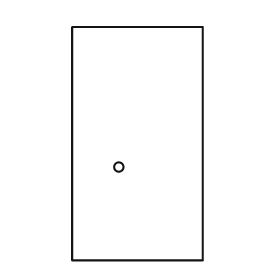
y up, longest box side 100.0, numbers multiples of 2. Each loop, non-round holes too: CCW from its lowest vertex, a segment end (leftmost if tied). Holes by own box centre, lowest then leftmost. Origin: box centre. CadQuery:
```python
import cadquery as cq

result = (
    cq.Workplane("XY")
    .moveTo(-28.0, -50.0)
    .lineTo(28.0, -50.0)
    .lineTo(28.0, 50.0)
    .lineTo(-28.0, 50.0)
    .close()
    .moveTo(-8.0, -10.0)
    .circle(2.0)
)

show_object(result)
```